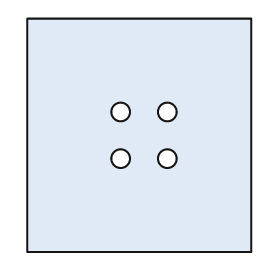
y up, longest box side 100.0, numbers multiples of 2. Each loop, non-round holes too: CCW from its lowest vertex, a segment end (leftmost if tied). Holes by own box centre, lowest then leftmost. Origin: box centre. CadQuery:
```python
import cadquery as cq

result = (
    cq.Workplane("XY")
    .moveTo(-48.0, -50.0)
    .lineTo(48.0, -50.0)
    .lineTo(48.0, 50.0)
    .lineTo(-48.0, 50.0)
    .close()
    .moveTo(-8.0, -10.0)
    .circle(4.0)
    .moveTo(12.0, -10.0)
    .circle(4.0)
    .moveTo(-8.0, 10.0)
    .circle(4.0)
    .moveTo(12.0, 10.0)
    .circle(4.0)
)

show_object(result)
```